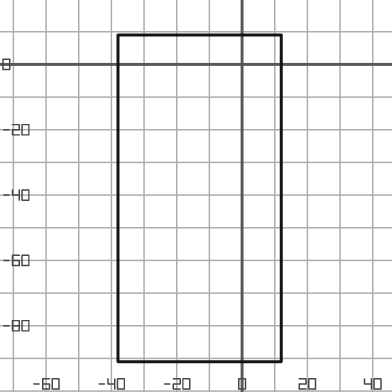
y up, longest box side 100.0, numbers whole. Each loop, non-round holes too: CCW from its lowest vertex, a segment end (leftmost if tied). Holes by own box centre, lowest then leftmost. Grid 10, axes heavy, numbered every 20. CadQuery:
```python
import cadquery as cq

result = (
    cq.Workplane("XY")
    .moveTo(-38.0, -91.0)
    .lineTo(12.0, -91.0)
    .lineTo(12.0, 9.0)
    .lineTo(-38.0, 9.0)
    .close()
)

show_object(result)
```